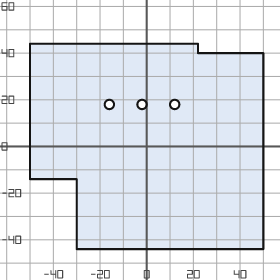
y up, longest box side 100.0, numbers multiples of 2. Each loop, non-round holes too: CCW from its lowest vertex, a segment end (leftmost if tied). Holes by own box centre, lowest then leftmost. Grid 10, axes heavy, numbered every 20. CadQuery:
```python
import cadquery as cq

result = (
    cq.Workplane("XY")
    .moveTo(-30.0, -44.0)
    .lineTo(50.0, -44.0)
    .lineTo(50.0, 40.0)
    .lineTo(22.0, 40.0)
    .lineTo(22.0, 44.0)
    .lineTo(-50.0, 44.0)
    .lineTo(-50.0, -14.0)
    .lineTo(-30.0, -14.0)
    .close()
    .moveTo(-16.0, 18.0)
    .circle(2.0)
    .moveTo(-2.0, 18.0)
    .circle(2.0)
    .moveTo(12.0, 18.0)
    .circle(2.0)
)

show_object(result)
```